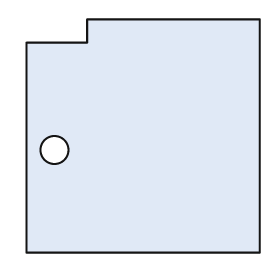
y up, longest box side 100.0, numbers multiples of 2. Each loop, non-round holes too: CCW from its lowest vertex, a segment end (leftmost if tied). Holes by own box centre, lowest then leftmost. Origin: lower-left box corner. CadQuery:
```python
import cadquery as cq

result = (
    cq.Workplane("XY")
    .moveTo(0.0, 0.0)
    .lineTo(100.0, 0.0)
    .lineTo(100.0, 100.0)
    .lineTo(26.0, 100.0)
    .lineTo(26.0, 90.0)
    .lineTo(0.0, 90.0)
    .close()
    .moveTo(12.0, 44.0)
    .circle(6.0)
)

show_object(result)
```